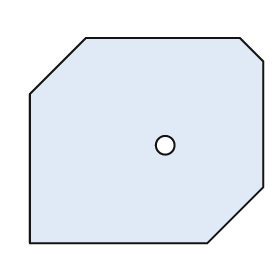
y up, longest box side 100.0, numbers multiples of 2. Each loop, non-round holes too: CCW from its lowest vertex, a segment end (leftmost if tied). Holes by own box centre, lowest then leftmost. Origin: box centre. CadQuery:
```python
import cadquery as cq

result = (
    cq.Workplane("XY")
    .moveTo(-50.0, -44.0)
    .lineTo(26.0, -44.0)
    .lineTo(50.0, -20.0)
    .lineTo(50.0, 34.0)
    .lineTo(40.0, 44.0)
    .lineTo(-26.0, 44.0)
    .lineTo(-50.0, 20.0)
    .close()
    .moveTo(8.0, -2.0)
    .circle(4.0)
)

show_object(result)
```